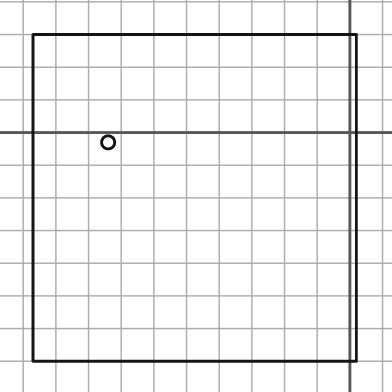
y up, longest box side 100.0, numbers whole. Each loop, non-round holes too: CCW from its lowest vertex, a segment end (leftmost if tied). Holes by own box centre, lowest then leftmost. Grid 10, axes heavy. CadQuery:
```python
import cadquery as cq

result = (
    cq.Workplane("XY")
    .moveTo(-97.0, -70.0)
    .lineTo(2.0, -70.0)
    .lineTo(2.0, 30.0)
    .lineTo(-97.0, 30.0)
    .close()
    .moveTo(-74.0, -3.0)
    .circle(2.0)
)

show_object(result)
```